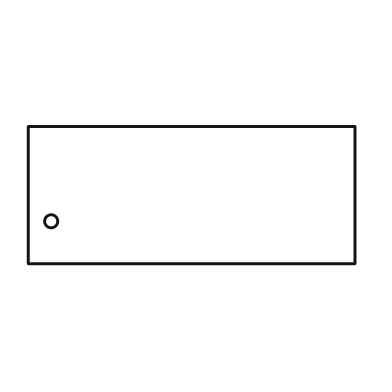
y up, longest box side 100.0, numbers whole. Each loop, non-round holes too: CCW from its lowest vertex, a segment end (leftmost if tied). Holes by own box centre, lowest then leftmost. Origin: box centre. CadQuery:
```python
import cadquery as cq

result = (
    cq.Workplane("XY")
    .moveTo(-50.0, -21.0)
    .lineTo(50.0, -21.0)
    .lineTo(50.0, 21.0)
    .lineTo(-50.0, 21.0)
    .close()
    .moveTo(-43.0, -8.0)
    .circle(2.0)
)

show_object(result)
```